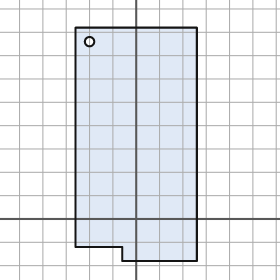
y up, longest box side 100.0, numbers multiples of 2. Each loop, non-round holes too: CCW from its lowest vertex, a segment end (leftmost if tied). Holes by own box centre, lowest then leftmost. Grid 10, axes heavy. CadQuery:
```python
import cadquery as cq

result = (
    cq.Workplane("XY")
    .moveTo(-6.0, -18.0)
    .lineTo(26.0, -18.0)
    .lineTo(26.0, 82.0)
    .lineTo(-26.0, 82.0)
    .lineTo(-26.0, -12.0)
    .lineTo(-6.0, -12.0)
    .close()
    .moveTo(-20.0, 76.0)
    .circle(2.0)
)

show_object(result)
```